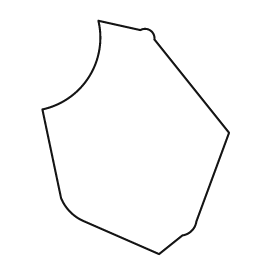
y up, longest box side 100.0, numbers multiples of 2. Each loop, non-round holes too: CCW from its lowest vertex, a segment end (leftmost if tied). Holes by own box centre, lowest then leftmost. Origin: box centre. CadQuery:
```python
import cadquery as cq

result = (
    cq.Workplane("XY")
    .moveTo(10.0, -50.0)
    .lineTo(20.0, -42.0)
    .threePointArc((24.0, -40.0), (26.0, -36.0))
    .lineTo(40.0, 2.0)
    .lineTo(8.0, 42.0)
    .threePointArc((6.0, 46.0), (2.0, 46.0))
    .lineTo(-16.0, 50.0)
    .threePointArc((-20.0, 26.0), (-40.0, 12.0))
    .lineTo(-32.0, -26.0)
    .threePointArc((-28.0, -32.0), (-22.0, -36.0))
    .close()
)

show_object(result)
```